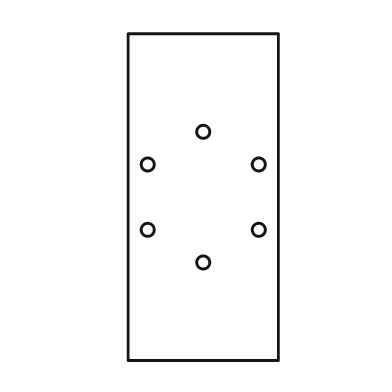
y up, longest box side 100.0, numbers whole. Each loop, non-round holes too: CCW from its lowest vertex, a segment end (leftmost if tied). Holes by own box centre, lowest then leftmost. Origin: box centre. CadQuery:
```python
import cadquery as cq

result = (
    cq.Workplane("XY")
    .moveTo(-23.0, -50.0)
    .lineTo(23.0, -50.0)
    .lineTo(23.0, 50.0)
    .lineTo(-23.0, 50.0)
    .close()
    .moveTo(0.0, -20.0)
    .circle(2.0)
    .moveTo(-17.0, -10.0)
    .circle(2.0)
    .moveTo(17.0, -10.0)
    .circle(2.0)
    .moveTo(-17.0, 10.0)
    .circle(2.0)
    .moveTo(17.0, 10.0)
    .circle(2.0)
    .moveTo(0.0, 20.0)
    .circle(2.0)
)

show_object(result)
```